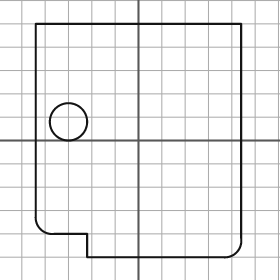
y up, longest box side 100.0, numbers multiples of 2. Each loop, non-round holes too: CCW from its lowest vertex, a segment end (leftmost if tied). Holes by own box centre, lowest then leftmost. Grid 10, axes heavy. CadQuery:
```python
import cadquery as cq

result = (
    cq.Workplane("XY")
    .moveTo(-22.0, -50.0)
    .lineTo(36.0, -50.0)
    .threePointArc((42.0, -48.0), (44.0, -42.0))
    .lineTo(44.0, 50.0)
    .lineTo(-44.0, 50.0)
    .lineTo(-44.0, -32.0)
    .threePointArc((-42.0, -38.0), (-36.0, -40.0))
    .lineTo(-22.0, -40.0)
    .close()
    .moveTo(-30.0, 8.0)
    .circle(8.0)
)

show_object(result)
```